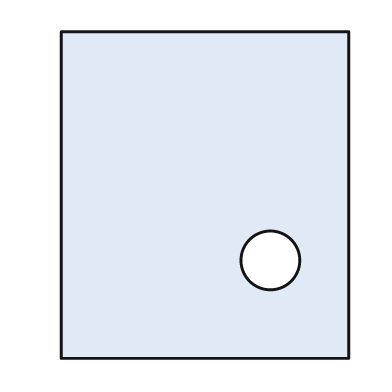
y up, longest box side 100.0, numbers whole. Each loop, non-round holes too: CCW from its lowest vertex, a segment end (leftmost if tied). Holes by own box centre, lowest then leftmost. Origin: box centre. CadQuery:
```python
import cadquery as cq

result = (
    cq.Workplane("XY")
    .moveTo(-44.0, -50.0)
    .lineTo(44.0, -50.0)
    .lineTo(44.0, 50.0)
    .lineTo(-44.0, 50.0)
    .close()
    .moveTo(20.0, -20.0)
    .circle(9.0)
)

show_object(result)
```